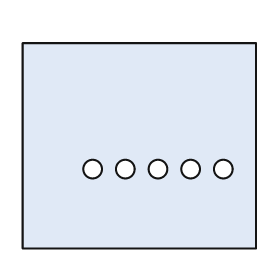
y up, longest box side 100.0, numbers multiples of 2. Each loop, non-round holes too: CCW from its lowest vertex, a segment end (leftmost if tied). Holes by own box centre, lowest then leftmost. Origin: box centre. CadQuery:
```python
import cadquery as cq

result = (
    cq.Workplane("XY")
    .moveTo(-50.0, -44.0)
    .lineTo(50.0, -44.0)
    .lineTo(50.0, 44.0)
    .lineTo(-50.0, 44.0)
    .close()
    .moveTo(-20.0, -10.0)
    .circle(4.0)
    .moveTo(-6.0, -10.0)
    .circle(4.0)
    .moveTo(8.0, -10.0)
    .circle(4.0)
    .moveTo(22.0, -10.0)
    .circle(4.0)
    .moveTo(36.0, -10.0)
    .circle(4.0)
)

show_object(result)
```